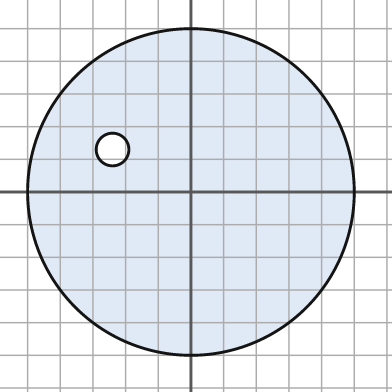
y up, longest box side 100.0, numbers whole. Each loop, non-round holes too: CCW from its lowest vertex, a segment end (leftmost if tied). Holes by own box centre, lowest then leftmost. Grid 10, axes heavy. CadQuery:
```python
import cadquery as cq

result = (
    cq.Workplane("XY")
    .moveTo(0.0, 0.0)
    .circle(50.0)
    .moveTo(-24.0, 13.0)
    .circle(5.0)
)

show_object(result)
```